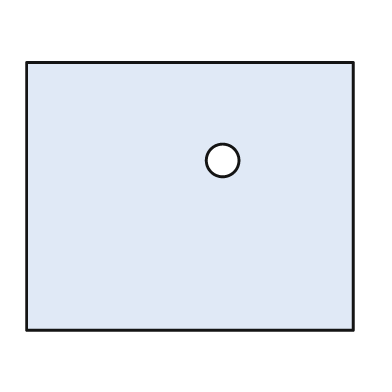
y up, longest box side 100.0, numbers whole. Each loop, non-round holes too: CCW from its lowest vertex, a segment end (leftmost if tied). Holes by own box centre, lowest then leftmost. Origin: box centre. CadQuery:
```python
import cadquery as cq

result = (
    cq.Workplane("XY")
    .moveTo(-50.0, -41.0)
    .lineTo(50.0, -41.0)
    .lineTo(50.0, 41.0)
    .lineTo(-50.0, 41.0)
    .close()
    .moveTo(10.0, 11.0)
    .circle(5.0)
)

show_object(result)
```